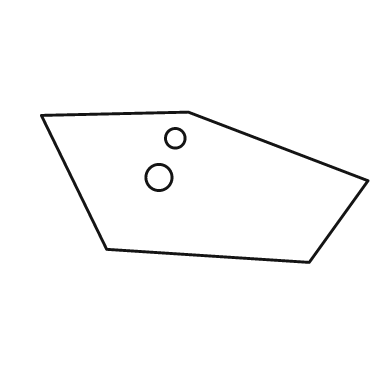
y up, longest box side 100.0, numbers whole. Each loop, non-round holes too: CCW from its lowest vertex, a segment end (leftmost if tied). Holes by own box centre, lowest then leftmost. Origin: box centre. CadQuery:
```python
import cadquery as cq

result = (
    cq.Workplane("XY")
    .moveTo(32.0, -23.0)
    .lineTo(50.0, 2.0)
    .lineTo(-5.0, 23.0)
    .lineTo(-50.0, 22.0)
    .lineTo(-30.0, -19.0)
    .close()
    .moveTo(-14.0, 3.0)
    .circle(4.0)
    .moveTo(-9.0, 15.0)
    .circle(3.0)
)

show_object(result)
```